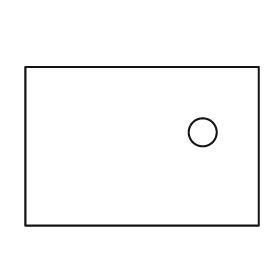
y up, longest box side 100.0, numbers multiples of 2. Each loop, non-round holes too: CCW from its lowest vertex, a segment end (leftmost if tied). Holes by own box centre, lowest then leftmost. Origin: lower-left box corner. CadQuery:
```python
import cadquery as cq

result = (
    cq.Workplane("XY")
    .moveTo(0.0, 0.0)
    .lineTo(100.0, 0.0)
    .lineTo(100.0, 68.0)
    .lineTo(0.0, 68.0)
    .close()
    .moveTo(76.0, 40.0)
    .circle(6.0)
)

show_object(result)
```